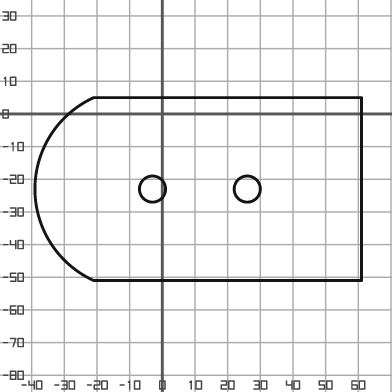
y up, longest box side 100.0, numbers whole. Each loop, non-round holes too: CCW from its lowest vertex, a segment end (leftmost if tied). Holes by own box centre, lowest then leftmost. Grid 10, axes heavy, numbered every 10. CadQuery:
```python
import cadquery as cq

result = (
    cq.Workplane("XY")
    .moveTo(-21.0, -51.0)
    .lineTo(61.0, -51.0)
    .lineTo(61.0, 5.0)
    .lineTo(-21.0, 5.0)
    .threePointArc((-39.0, -23.0), (-21.0, -51.0))
    .close()
    .moveTo(-3.0, -23.0)
    .circle(4.0)
    .moveTo(26.0, -23.0)
    .circle(4.0)
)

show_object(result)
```